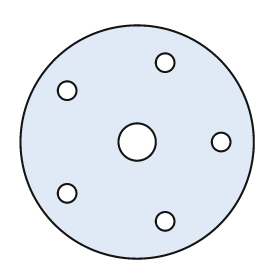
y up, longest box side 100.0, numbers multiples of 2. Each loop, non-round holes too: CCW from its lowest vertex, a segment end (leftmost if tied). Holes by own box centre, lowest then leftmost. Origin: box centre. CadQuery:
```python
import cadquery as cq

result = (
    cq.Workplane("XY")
    .moveTo(0.0, 0.0)
    .circle(50.0)
    .moveTo(12.0, -34.0)
    .circle(4.0)
    .moveTo(-30.0, -22.0)
    .circle(4.0)
    .moveTo(0.0, 0.0)
    .circle(8.0)
    .moveTo(36.0, 0.0)
    .circle(4.0)
    .moveTo(-30.0, 22.0)
    .circle(4.0)
    .moveTo(12.0, 34.0)
    .circle(4.0)
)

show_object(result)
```